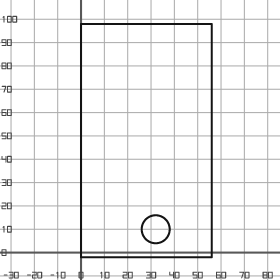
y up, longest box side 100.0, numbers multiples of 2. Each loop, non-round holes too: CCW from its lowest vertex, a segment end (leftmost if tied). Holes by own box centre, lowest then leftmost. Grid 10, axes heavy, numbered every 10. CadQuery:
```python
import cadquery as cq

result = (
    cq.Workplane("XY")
    .moveTo(0.0, -2.0)
    .lineTo(56.0, -2.0)
    .lineTo(56.0, 98.0)
    .lineTo(0.0, 98.0)
    .close()
    .moveTo(32.0, 10.0)
    .circle(6.0)
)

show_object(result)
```